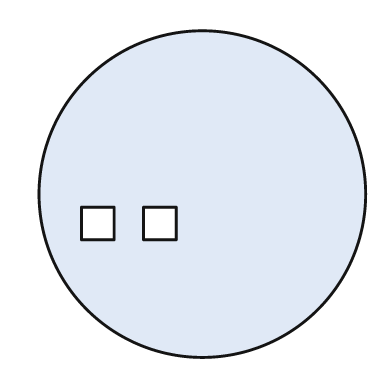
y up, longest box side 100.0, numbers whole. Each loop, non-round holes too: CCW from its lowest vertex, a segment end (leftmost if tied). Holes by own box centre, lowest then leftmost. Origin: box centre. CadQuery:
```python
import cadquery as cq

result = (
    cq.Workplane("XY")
    .moveTo(0.0, 0.0)
    .circle(50.0)
    .moveTo(-37.0, -14.0)
    .lineTo(-27.0, -14.0)
    .lineTo(-27.0, -4.0)
    .lineTo(-37.0, -4.0)
    .close()
    .moveTo(-18.0, -14.0)
    .lineTo(-8.0, -14.0)
    .lineTo(-8.0, -4.0)
    .lineTo(-18.0, -4.0)
    .close()
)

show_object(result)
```